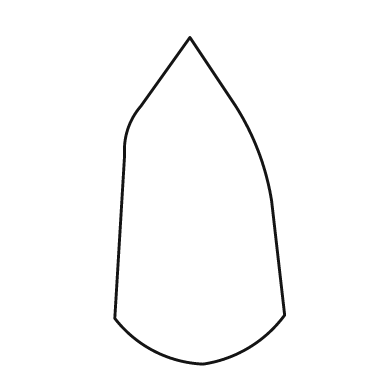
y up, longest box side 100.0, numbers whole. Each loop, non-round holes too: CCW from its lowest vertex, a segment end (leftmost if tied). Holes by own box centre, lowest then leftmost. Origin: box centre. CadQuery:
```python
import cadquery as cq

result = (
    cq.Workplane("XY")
    .moveTo(1.0, -50.0)
    .threePointArc((15.0, -45.0), (26.0, -35.0))
    .lineTo(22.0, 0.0)
    .threePointArc((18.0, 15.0), (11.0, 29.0))
    .lineTo(-3.0, 50.0)
    .lineTo(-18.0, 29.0)
    .threePointArc((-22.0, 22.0), (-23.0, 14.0))
    .lineTo(-26.0, -36.0)
    .threePointArc((-14.0, -46.0), (1.0, -50.0))
    .close()
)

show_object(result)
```